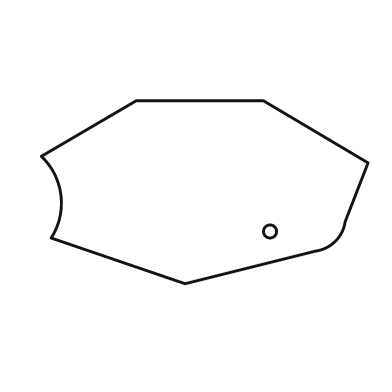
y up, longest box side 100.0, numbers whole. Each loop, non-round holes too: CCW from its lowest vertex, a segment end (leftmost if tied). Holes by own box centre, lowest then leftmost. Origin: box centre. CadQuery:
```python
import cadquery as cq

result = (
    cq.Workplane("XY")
    .moveTo(-6.0, -28.0)
    .lineTo(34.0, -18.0)
    .threePointArc((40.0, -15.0), (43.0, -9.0))
    .lineTo(50.0, 9.0)
    .lineTo(18.0, 28.0)
    .lineTo(-21.0, 28.0)
    .lineTo(-50.0, 11.0)
    .threePointArc((-44.0, -1.0), (-47.0, -14.0))
    .close()
    .moveTo(20.0, -12.0)
    .circle(2.0)
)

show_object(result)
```